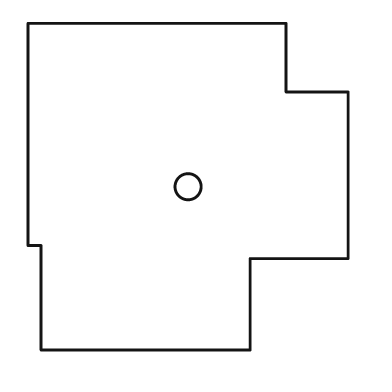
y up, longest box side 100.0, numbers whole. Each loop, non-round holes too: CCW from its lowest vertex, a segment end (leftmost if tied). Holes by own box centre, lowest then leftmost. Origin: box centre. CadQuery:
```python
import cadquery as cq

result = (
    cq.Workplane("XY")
    .moveTo(-45.0, -50.0)
    .lineTo(19.0, -50.0)
    .lineTo(19.0, -22.0)
    .lineTo(49.0, -22.0)
    .lineTo(49.0, 29.0)
    .lineTo(30.0, 29.0)
    .lineTo(30.0, 50.0)
    .lineTo(-49.0, 50.0)
    .lineTo(-49.0, -18.0)
    .lineTo(-45.0, -18.0)
    .close()
    .moveTo(0.0, 0.0)
    .circle(4.0)
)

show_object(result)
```